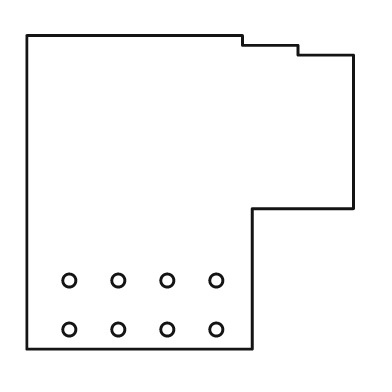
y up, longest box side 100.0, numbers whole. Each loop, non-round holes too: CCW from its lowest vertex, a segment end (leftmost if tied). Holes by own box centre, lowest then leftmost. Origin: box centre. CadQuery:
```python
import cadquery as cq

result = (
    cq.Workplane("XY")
    .moveTo(-50.0, -48.0)
    .lineTo(19.0, -48.0)
    .lineTo(19.0, -5.0)
    .lineTo(50.0, -5.0)
    .lineTo(50.0, 42.0)
    .lineTo(33.0, 42.0)
    .lineTo(33.0, 45.0)
    .lineTo(16.0, 45.0)
    .lineTo(16.0, 48.0)
    .lineTo(-50.0, 48.0)
    .close()
    .moveTo(-37.0, -42.0)
    .circle(2.0)
    .moveTo(-22.0, -42.0)
    .circle(2.0)
    .moveTo(-7.0, -42.0)
    .circle(2.0)
    .moveTo(8.0, -42.0)
    .circle(2.0)
    .moveTo(-37.0, -27.0)
    .circle(2.0)
    .moveTo(-22.0, -27.0)
    .circle(2.0)
    .moveTo(-7.0, -27.0)
    .circle(2.0)
    .moveTo(8.0, -27.0)
    .circle(2.0)
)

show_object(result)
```